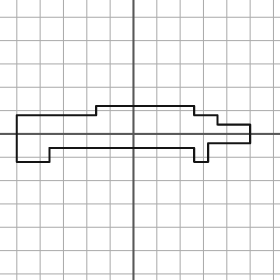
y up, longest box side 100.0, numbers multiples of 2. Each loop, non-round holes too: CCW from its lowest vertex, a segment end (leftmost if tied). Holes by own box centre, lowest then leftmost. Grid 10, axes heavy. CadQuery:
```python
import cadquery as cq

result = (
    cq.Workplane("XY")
    .moveTo(-50.0, -12.0)
    .lineTo(-36.0, -12.0)
    .lineTo(-36.0, -6.0)
    .lineTo(26.0, -6.0)
    .lineTo(26.0, -12.0)
    .lineTo(32.0, -12.0)
    .lineTo(32.0, -4.0)
    .lineTo(50.0, -4.0)
    .lineTo(50.0, 4.0)
    .lineTo(36.0, 4.0)
    .lineTo(36.0, 8.0)
    .lineTo(26.0, 8.0)
    .lineTo(26.0, 12.0)
    .lineTo(-16.0, 12.0)
    .lineTo(-16.0, 8.0)
    .lineTo(-50.0, 8.0)
    .close()
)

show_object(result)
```